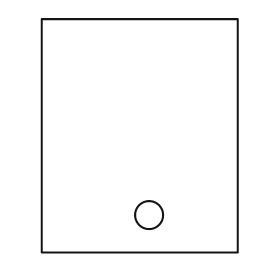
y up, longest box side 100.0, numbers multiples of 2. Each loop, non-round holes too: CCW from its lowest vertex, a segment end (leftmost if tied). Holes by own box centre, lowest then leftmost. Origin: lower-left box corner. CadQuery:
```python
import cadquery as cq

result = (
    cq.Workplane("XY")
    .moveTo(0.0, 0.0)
    .lineTo(84.0, 0.0)
    .lineTo(84.0, 100.0)
    .lineTo(0.0, 100.0)
    .close()
    .moveTo(46.0, 16.0)
    .circle(6.0)
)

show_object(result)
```